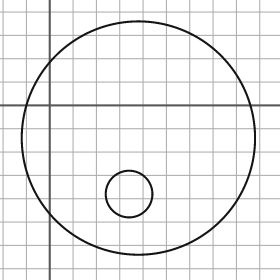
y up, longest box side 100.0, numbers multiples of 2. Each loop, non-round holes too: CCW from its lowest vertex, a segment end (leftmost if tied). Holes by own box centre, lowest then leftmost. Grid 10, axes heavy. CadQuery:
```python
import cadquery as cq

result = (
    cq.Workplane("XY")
    .moveTo(38.0, -14.0)
    .circle(50.0)
    .moveTo(34.0, -38.0)
    .circle(10.0)
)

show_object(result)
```